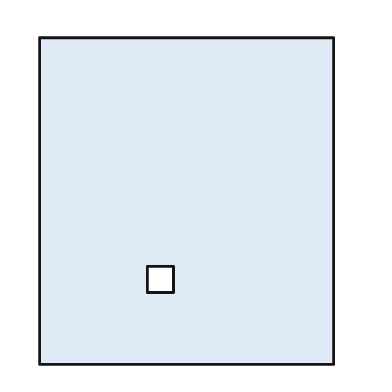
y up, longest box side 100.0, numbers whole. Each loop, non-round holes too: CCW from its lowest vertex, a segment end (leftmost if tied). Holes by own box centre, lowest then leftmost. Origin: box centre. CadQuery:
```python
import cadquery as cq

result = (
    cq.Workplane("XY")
    .moveTo(-45.0, -50.0)
    .lineTo(45.0, -50.0)
    .lineTo(45.0, 50.0)
    .lineTo(-45.0, 50.0)
    .close()
    .moveTo(-12.0, -28.0)
    .lineTo(-4.0, -28.0)
    .lineTo(-4.0, -20.0)
    .lineTo(-12.0, -20.0)
    .close()
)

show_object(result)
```